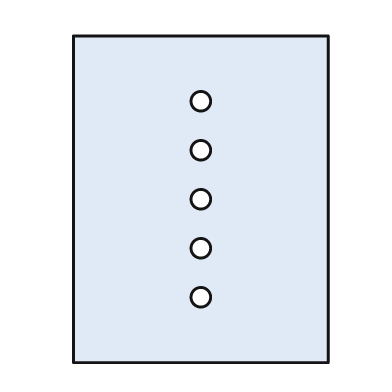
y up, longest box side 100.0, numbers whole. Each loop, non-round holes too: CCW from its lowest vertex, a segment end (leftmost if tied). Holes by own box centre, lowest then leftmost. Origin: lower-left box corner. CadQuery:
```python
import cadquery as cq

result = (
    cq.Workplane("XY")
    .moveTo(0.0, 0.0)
    .lineTo(78.0, 0.0)
    .lineTo(78.0, 100.0)
    .lineTo(0.0, 100.0)
    .close()
    .moveTo(39.0, 20.0)
    .circle(3.0)
    .moveTo(39.0, 35.0)
    .circle(3.0)
    .moveTo(39.0, 50.0)
    .circle(3.0)
    .moveTo(39.0, 65.0)
    .circle(3.0)
    .moveTo(39.0, 80.0)
    .circle(3.0)
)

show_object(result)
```